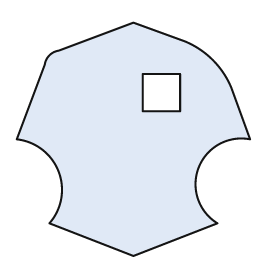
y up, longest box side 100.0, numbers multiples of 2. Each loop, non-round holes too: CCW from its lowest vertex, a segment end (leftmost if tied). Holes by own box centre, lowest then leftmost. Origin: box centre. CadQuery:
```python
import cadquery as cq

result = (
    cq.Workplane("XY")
    .moveTo(0.0, -50.0)
    .lineTo(36.0, -36.0)
    .threePointArc((28.0, -12.0), (50.0, 0.0))
    .lineTo(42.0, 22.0)
    .threePointArc((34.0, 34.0), (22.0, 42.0))
    .lineTo(0.0, 50.0)
    .lineTo(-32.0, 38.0)
    .threePointArc((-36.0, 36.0), (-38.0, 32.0))
    .lineTo(-50.0, 0.0)
    .threePointArc((-32.0, -14.0), (-36.0, -36.0))
    .close()
    .moveTo(4.0, 12.0)
    .lineTo(20.0, 12.0)
    .lineTo(20.0, 28.0)
    .lineTo(4.0, 28.0)
    .close()
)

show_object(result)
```